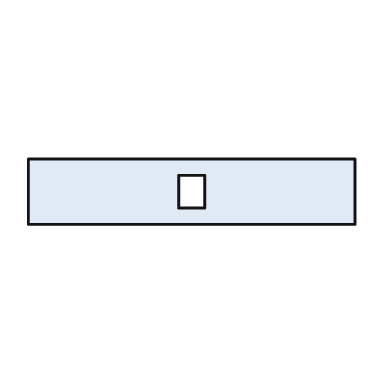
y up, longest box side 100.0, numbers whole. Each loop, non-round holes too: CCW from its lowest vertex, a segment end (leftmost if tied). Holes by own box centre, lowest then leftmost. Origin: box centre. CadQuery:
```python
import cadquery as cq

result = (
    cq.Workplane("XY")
    .moveTo(-50.0, -10.0)
    .lineTo(50.0, -10.0)
    .lineTo(50.0, 10.0)
    .lineTo(-50.0, 10.0)
    .close()
    .moveTo(-4.0, -5.0)
    .lineTo(4.0, -5.0)
    .lineTo(4.0, 5.0)
    .lineTo(-4.0, 5.0)
    .close()
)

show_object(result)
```